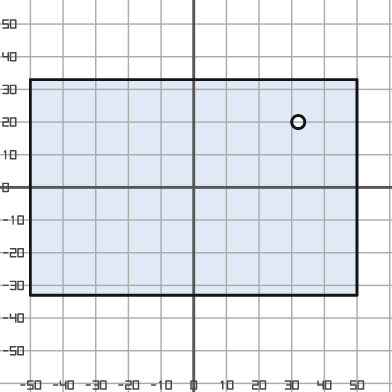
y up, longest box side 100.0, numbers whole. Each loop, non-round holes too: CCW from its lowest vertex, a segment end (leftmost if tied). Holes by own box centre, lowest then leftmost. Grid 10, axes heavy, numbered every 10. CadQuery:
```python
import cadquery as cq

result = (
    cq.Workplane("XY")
    .moveTo(-50.0, -33.0)
    .lineTo(50.0, -33.0)
    .lineTo(50.0, 33.0)
    .lineTo(-50.0, 33.0)
    .close()
    .moveTo(32.0, 20.0)
    .circle(2.0)
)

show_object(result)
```